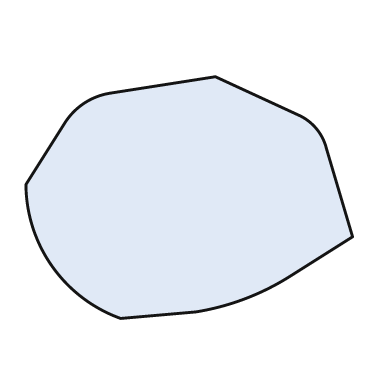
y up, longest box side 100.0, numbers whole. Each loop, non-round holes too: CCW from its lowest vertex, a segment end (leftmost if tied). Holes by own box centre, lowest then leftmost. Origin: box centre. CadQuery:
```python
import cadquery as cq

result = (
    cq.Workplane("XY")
    .moveTo(-21.0, -37.0)
    .lineTo(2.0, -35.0)
    .threePointArc((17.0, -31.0), (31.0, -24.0))
    .lineTo(50.0, -12.0)
    .lineTo(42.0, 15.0)
    .threePointArc((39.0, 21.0), (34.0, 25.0))
    .lineTo(8.0, 37.0)
    .lineTo(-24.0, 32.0)
    .threePointArc((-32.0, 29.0), (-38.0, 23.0))
    .lineTo(-50.0, 4.0)
    .threePointArc((-42.0, -21.0), (-21.0, -37.0))
    .close()
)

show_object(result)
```